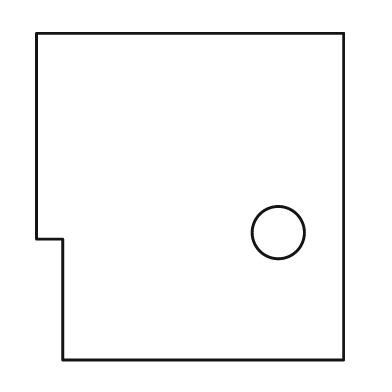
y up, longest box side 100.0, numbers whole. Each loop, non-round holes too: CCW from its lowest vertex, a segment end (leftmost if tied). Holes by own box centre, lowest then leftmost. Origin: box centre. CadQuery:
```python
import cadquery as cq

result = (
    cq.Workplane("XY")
    .moveTo(-39.0, -50.0)
    .lineTo(47.0, -50.0)
    .lineTo(47.0, 50.0)
    .lineTo(-47.0, 50.0)
    .lineTo(-47.0, -13.0)
    .lineTo(-39.0, -13.0)
    .close()
    .moveTo(27.0, -11.0)
    .circle(8.0)
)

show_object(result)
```